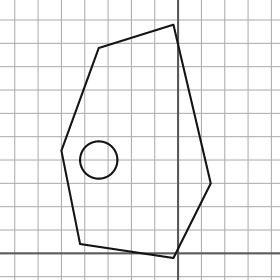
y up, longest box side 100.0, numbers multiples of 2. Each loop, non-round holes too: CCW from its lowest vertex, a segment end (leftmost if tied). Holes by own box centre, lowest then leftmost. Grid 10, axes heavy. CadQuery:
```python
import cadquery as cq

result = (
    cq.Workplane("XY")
    .moveTo(-2.0, -2.0)
    .lineTo(14.0, 30.0)
    .lineTo(-2.0, 98.0)
    .lineTo(-34.0, 88.0)
    .lineTo(-50.0, 44.0)
    .lineTo(-42.0, 4.0)
    .close()
    .moveTo(-34.0, 40.0)
    .circle(8.0)
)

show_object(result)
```